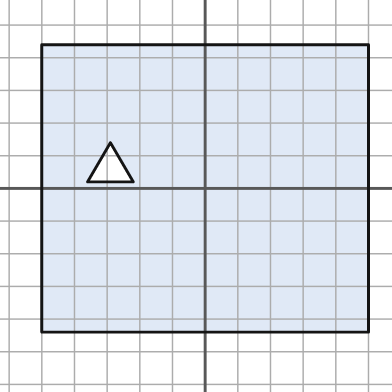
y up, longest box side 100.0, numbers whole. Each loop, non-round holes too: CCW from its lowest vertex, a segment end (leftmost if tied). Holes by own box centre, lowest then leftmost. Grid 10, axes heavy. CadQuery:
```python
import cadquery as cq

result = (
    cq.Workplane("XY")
    .moveTo(-50.0, -44.0)
    .lineTo(50.0, -44.0)
    .lineTo(50.0, 44.0)
    .lineTo(-50.0, 44.0)
    .close()
    .moveTo(-36.0, 2.0)
    .lineTo(-22.0, 2.0)
    .lineTo(-29.0, 14.0)
    .close()
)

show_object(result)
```